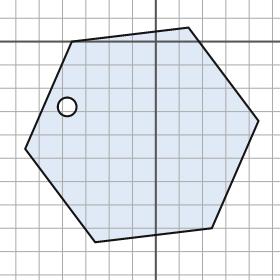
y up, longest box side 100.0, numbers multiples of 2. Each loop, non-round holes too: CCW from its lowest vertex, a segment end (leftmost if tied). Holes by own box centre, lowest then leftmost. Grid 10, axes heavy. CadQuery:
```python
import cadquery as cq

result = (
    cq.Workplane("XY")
    .moveTo(-26.0, -86.0)
    .lineTo(24.0, -80.0)
    .lineTo(44.0, -34.0)
    .lineTo(14.0, 6.0)
    .lineTo(-36.0, 0.0)
    .lineTo(-56.0, -46.0)
    .close()
    .moveTo(-38.0, -28.0)
    .circle(4.0)
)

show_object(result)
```